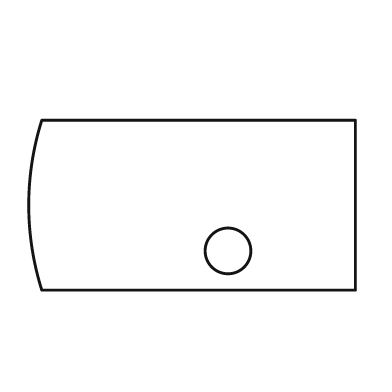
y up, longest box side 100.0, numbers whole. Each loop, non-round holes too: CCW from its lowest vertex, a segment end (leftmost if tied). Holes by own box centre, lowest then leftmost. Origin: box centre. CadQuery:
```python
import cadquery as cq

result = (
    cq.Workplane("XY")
    .moveTo(-46.0, -26.0)
    .lineTo(50.0, -26.0)
    .lineTo(50.0, 26.0)
    .lineTo(-46.0, 26.0)
    .threePointArc((-50.0, 0.0), (-46.0, -26.0))
    .close()
    .moveTo(11.0, -14.0)
    .circle(7.0)
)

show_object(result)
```